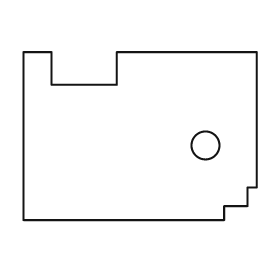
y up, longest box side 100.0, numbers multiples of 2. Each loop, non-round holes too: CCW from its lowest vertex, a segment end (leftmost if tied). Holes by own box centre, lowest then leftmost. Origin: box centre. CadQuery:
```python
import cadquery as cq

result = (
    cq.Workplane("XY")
    .moveTo(-50.0, -36.0)
    .lineTo(36.0, -36.0)
    .lineTo(36.0, -30.0)
    .lineTo(46.0, -30.0)
    .lineTo(46.0, -22.0)
    .lineTo(50.0, -22.0)
    .lineTo(50.0, 36.0)
    .lineTo(-10.0, 36.0)
    .lineTo(-10.0, 22.0)
    .lineTo(-38.0, 22.0)
    .lineTo(-38.0, 36.0)
    .lineTo(-50.0, 36.0)
    .close()
    .moveTo(28.0, -4.0)
    .circle(6.0)
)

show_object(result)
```